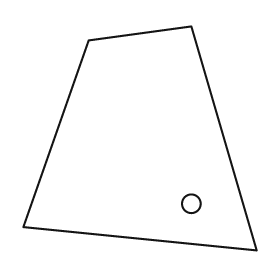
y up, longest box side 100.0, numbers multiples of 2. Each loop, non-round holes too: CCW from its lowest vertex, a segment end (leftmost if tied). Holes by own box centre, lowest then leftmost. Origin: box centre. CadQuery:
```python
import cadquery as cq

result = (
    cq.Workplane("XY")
    .moveTo(50.0, -48.0)
    .lineTo(22.0, 48.0)
    .lineTo(-22.0, 42.0)
    .lineTo(-50.0, -38.0)
    .close()
    .moveTo(22.0, -28.0)
    .circle(4.0)
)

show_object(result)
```